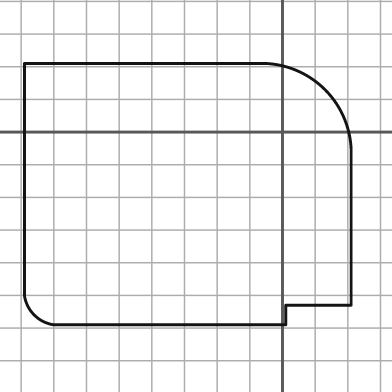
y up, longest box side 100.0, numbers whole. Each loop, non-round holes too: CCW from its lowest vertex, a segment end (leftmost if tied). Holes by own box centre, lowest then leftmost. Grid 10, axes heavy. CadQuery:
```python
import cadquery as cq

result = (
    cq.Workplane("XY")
    .moveTo(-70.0, -59.0)
    .lineTo(1.0, -59.0)
    .lineTo(1.0, -53.0)
    .lineTo(21.0, -53.0)
    .lineTo(21.0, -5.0)
    .threePointArc((13.0, 13.0), (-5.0, 21.0))
    .lineTo(-79.0, 21.0)
    .lineTo(-79.0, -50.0)
    .threePointArc((-76.0, -56.0), (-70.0, -59.0))
    .close()
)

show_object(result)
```